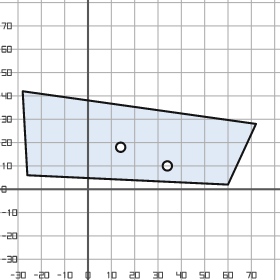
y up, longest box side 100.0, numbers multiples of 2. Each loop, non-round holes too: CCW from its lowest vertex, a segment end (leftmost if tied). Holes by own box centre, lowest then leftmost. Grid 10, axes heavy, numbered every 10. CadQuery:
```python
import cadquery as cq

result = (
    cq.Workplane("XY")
    .moveTo(60.0, 2.0)
    .lineTo(72.0, 28.0)
    .lineTo(-28.0, 42.0)
    .lineTo(-26.0, 6.0)
    .close()
    .moveTo(34.0, 10.0)
    .circle(2.0)
    .moveTo(14.0, 18.0)
    .circle(2.0)
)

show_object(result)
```